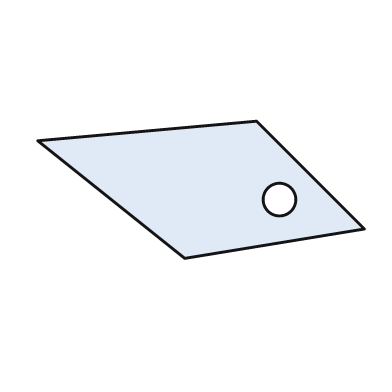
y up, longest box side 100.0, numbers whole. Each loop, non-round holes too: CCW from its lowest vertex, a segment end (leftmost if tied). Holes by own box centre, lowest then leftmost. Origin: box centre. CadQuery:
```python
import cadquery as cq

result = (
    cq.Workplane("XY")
    .moveTo(-5.0, -21.0)
    .lineTo(50.0, -12.0)
    .lineTo(17.0, 21.0)
    .lineTo(-50.0, 15.0)
    .close()
    .moveTo(24.0, -3.0)
    .circle(5.0)
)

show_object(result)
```